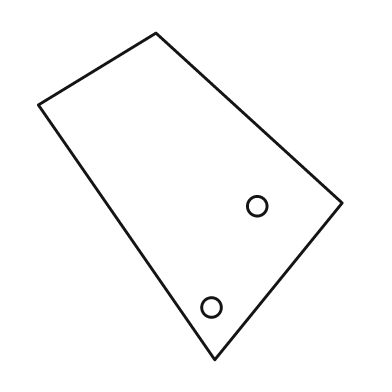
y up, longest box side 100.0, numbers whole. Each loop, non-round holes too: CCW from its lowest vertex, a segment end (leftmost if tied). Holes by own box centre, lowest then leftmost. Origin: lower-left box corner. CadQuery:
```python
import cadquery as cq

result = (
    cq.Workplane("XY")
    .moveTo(54.0, 0.0)
    .lineTo(93.0, 48.0)
    .lineTo(36.0, 100.0)
    .lineTo(0.0, 78.0)
    .close()
    .moveTo(53.0, 16.0)
    .circle(3.0)
    .moveTo(67.0, 47.0)
    .circle(3.0)
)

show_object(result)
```